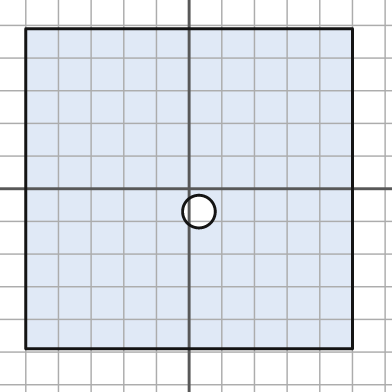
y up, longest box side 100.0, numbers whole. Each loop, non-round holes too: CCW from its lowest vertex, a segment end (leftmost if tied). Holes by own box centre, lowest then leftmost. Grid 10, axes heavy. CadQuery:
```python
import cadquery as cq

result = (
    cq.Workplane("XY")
    .moveTo(-50.0, -49.0)
    .lineTo(50.0, -49.0)
    .lineTo(50.0, 49.0)
    .lineTo(-50.0, 49.0)
    .close()
    .moveTo(3.0, -7.0)
    .circle(5.0)
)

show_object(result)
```